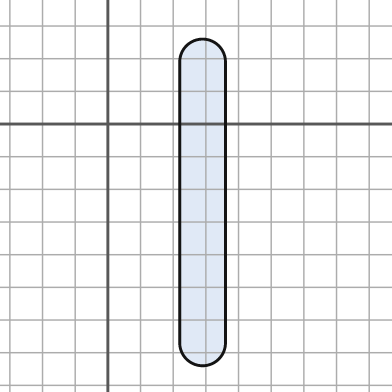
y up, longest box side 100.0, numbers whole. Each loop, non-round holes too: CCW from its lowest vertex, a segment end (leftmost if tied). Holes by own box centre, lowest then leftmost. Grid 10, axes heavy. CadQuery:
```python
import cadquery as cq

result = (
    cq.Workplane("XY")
    .moveTo(22.0, -67.0)
    .threePointArc((29.0, -74.0), (36.0, -67.0))
    .lineTo(36.0, 19.0)
    .threePointArc((29.0, 26.0), (22.0, 19.0))
    .close()
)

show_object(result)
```